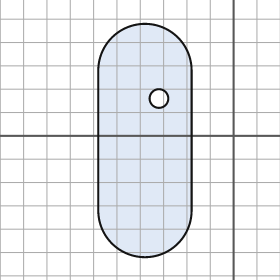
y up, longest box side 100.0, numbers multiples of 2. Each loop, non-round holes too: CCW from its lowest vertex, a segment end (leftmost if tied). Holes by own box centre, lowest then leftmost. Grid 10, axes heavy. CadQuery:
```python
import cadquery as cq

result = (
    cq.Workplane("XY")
    .moveTo(-58.0, -32.0)
    .threePointArc((-38.0, -52.0), (-18.0, -32.0))
    .lineTo(-18.0, 28.0)
    .threePointArc((-38.0, 48.0), (-58.0, 28.0))
    .close()
    .moveTo(-32.0, 16.0)
    .circle(4.0)
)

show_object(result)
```